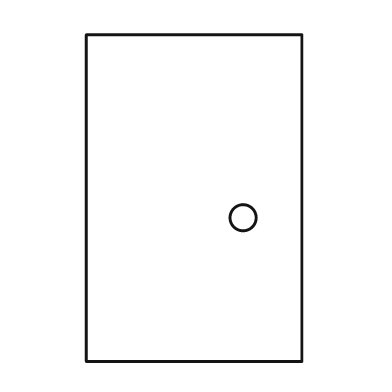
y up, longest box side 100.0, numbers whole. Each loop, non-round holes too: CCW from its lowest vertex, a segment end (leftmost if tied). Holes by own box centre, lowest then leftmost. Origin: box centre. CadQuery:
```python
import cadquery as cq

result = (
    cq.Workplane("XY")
    .moveTo(-33.0, -50.0)
    .lineTo(33.0, -50.0)
    .lineTo(33.0, 50.0)
    .lineTo(-33.0, 50.0)
    .close()
    .moveTo(15.0, -6.0)
    .circle(4.0)
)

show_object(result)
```